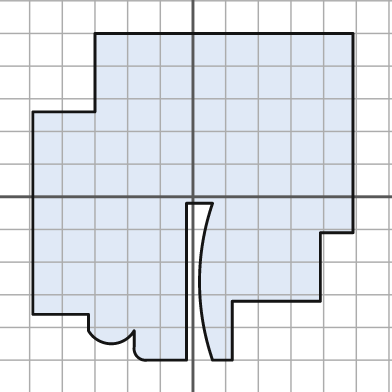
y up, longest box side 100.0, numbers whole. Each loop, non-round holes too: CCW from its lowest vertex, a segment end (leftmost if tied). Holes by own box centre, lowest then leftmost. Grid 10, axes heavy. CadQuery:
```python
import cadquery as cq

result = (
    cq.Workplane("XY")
    .moveTo(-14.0, -50.0)
    .lineTo(-2.0, -50.0)
    .lineTo(-2.0, -2.0)
    .lineTo(6.0, -2.0)
    .threePointArc((2.0, -26.0), (6.0, -50.0))
    .lineTo(12.0, -50.0)
    .lineTo(12.0, -32.0)
    .lineTo(39.0, -32.0)
    .lineTo(39.0, -11.0)
    .lineTo(49.0, -11.0)
    .lineTo(49.0, 50.0)
    .lineTo(-30.0, 50.0)
    .lineTo(-30.0, 26.0)
    .lineTo(-49.0, 26.0)
    .lineTo(-49.0, -36.0)
    .lineTo(-32.0, -36.0)
    .lineTo(-32.0, -41.0)
    .threePointArc((-25.0, -45.0), (-18.0, -41.0))
    .lineTo(-18.0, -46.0)
    .threePointArc((-17.0, -49.0), (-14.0, -50.0))
    .close()
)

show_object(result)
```